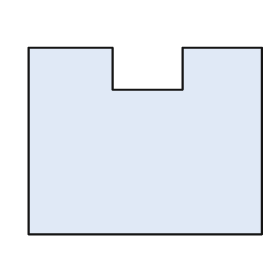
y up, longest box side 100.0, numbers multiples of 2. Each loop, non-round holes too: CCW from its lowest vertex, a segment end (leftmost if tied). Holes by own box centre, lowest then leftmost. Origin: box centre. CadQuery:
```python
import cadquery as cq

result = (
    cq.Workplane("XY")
    .moveTo(-50.0, -40.0)
    .lineTo(50.0, -40.0)
    .lineTo(50.0, 40.0)
    .lineTo(16.0, 40.0)
    .lineTo(16.0, 22.0)
    .lineTo(-14.0, 22.0)
    .lineTo(-14.0, 40.0)
    .lineTo(-50.0, 40.0)
    .close()
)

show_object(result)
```